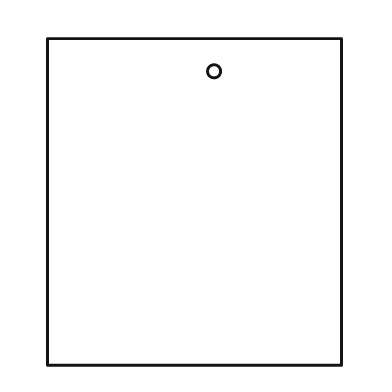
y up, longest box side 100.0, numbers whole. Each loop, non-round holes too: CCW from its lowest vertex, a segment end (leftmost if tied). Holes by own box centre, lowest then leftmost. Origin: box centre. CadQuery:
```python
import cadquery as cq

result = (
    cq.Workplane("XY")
    .moveTo(-45.0, -50.0)
    .lineTo(45.0, -50.0)
    .lineTo(45.0, 50.0)
    .lineTo(-45.0, 50.0)
    .close()
    .moveTo(6.0, 40.0)
    .circle(2.0)
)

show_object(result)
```